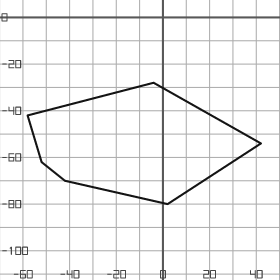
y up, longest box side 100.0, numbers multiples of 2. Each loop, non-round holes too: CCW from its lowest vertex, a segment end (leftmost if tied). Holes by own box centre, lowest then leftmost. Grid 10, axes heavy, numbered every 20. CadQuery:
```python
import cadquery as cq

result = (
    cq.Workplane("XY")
    .moveTo(2.0, -80.0)
    .lineTo(42.0, -54.0)
    .lineTo(-4.0, -28.0)
    .lineTo(-58.0, -42.0)
    .lineTo(-52.0, -62.0)
    .lineTo(-42.0, -70.0)
    .close()
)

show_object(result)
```